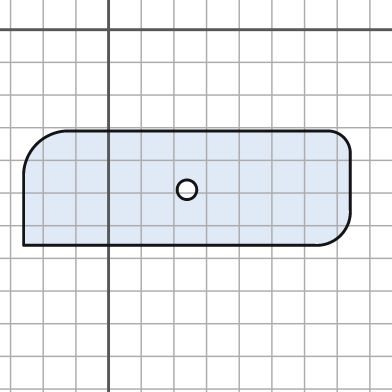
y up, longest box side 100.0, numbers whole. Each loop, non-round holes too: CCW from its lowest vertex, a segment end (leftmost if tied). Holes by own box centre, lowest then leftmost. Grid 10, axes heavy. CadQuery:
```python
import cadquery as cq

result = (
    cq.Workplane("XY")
    .moveTo(-26.0, -66.0)
    .lineTo(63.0, -66.0)
    .threePointArc((71.0, -63.0), (74.0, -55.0))
    .lineTo(74.0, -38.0)
    .threePointArc((72.0, -33.0), (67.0, -31.0))
    .lineTo(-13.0, -31.0)
    .threePointArc((-22.0, -35.0), (-26.0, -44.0))
    .close()
    .moveTo(24.0, -49.0)
    .circle(3.0)
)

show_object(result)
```